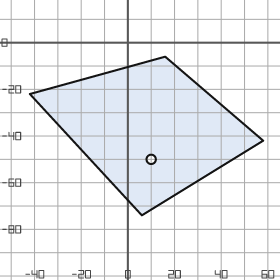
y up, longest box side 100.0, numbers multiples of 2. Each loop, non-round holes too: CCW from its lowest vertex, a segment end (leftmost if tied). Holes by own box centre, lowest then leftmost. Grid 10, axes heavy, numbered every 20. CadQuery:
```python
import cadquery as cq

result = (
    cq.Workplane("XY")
    .moveTo(6.0, -74.0)
    .lineTo(58.0, -42.0)
    .lineTo(16.0, -6.0)
    .lineTo(-42.0, -22.0)
    .close()
    .moveTo(10.0, -50.0)
    .circle(2.0)
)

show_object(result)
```